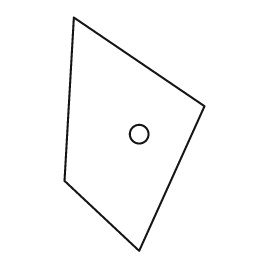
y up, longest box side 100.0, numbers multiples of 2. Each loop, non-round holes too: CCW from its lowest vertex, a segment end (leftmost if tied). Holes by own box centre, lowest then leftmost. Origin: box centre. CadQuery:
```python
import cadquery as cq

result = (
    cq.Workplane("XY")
    .moveTo(2.0, -50.0)
    .lineTo(30.0, 12.0)
    .lineTo(-26.0, 50.0)
    .lineTo(-30.0, -20.0)
    .close()
    .moveTo(2.0, 0.0)
    .circle(4.0)
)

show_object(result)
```